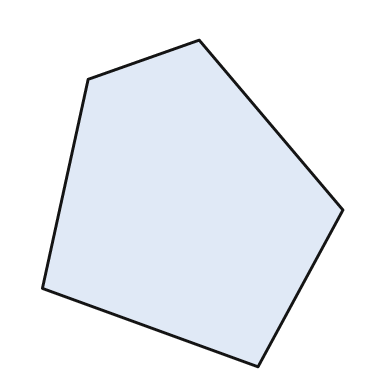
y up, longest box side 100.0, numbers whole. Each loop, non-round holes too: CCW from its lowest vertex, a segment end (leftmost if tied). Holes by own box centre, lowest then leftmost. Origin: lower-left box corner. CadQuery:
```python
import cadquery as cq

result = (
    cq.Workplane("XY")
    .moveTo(66.0, 0.0)
    .lineTo(92.0, 48.0)
    .lineTo(48.0, 100.0)
    .lineTo(14.0, 88.0)
    .lineTo(0.0, 24.0)
    .close()
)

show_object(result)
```